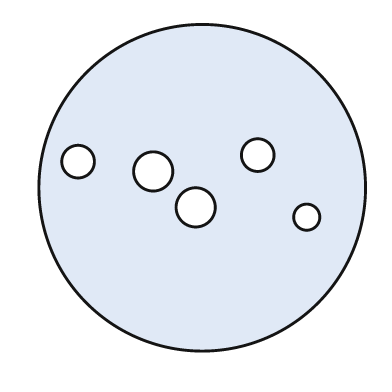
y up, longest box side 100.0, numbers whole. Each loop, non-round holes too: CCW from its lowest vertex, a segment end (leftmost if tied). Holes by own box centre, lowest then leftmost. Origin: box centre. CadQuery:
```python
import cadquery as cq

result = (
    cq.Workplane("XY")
    .moveTo(0.0, 0.0)
    .circle(50.0)
    .moveTo(32.0, -9.0)
    .circle(4.0)
    .moveTo(-2.0, -6.0)
    .circle(6.0)
    .moveTo(-15.0, 5.0)
    .circle(6.0)
    .moveTo(-38.0, 8.0)
    .circle(5.0)
    .moveTo(17.0, 10.0)
    .circle(5.0)
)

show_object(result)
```